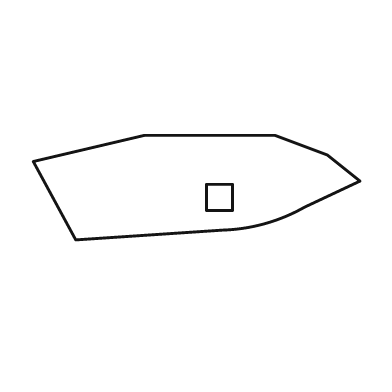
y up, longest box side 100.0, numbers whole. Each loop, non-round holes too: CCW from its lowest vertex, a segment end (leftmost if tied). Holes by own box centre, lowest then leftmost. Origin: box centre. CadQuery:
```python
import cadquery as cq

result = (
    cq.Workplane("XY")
    .moveTo(-37.0, -16.0)
    .lineTo(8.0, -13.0)
    .threePointArc((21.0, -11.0), (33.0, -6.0))
    .lineTo(50.0, 2.0)
    .lineTo(40.0, 10.0)
    .lineTo(24.0, 16.0)
    .lineTo(-16.0, 16.0)
    .lineTo(-50.0, 8.0)
    .close()
    .moveTo(3.0, -7.0)
    .lineTo(11.0, -7.0)
    .lineTo(11.0, 1.0)
    .lineTo(3.0, 1.0)
    .close()
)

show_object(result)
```